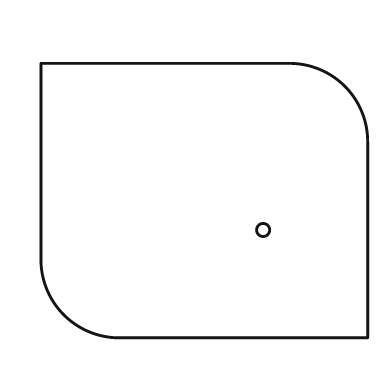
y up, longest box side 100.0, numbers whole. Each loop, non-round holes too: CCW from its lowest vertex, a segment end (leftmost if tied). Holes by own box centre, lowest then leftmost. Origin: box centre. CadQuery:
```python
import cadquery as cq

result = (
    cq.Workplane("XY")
    .moveTo(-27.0, -42.0)
    .lineTo(50.0, -42.0)
    .lineTo(50.0, 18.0)
    .threePointArc((43.0, 35.0), (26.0, 42.0))
    .lineTo(-50.0, 42.0)
    .lineTo(-50.0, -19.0)
    .threePointArc((-43.0, -35.0), (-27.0, -42.0))
    .close()
    .moveTo(18.0, -9.0)
    .circle(2.0)
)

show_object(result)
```